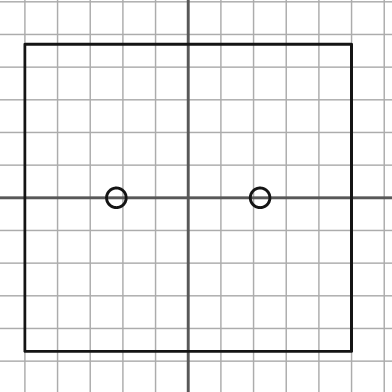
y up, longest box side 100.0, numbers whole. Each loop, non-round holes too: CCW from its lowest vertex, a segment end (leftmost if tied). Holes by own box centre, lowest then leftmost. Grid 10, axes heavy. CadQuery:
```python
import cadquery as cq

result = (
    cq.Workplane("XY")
    .moveTo(-50.0, -47.0)
    .lineTo(50.0, -47.0)
    .lineTo(50.0, 47.0)
    .lineTo(-50.0, 47.0)
    .close()
    .moveTo(-22.0, 0.0)
    .circle(3.0)
    .moveTo(22.0, 0.0)
    .circle(3.0)
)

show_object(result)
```